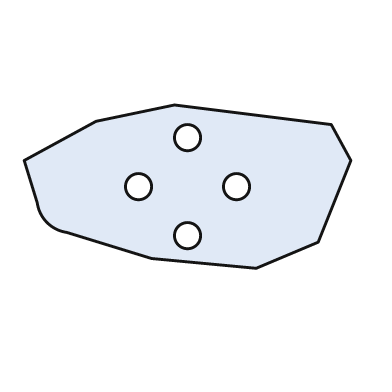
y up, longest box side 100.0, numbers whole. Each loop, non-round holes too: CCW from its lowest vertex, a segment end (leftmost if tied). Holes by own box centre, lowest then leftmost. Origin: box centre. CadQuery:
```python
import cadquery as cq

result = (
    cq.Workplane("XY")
    .moveTo(21.0, -25.0)
    .lineTo(40.0, -17.0)
    .lineTo(50.0, 8.0)
    .lineTo(44.0, 19.0)
    .lineTo(-4.0, 25.0)
    .lineTo(-28.0, 20.0)
    .lineTo(-50.0, 8.0)
    .lineTo(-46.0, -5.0)
    .threePointArc((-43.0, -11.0), (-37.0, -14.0))
    .lineTo(-11.0, -22.0)
    .close()
    .moveTo(0.0, -15.0)
    .circle(4.0)
    .moveTo(-15.0, 0.0)
    .circle(4.0)
    .moveTo(15.0, 0.0)
    .circle(4.0)
    .moveTo(0.0, 15.0)
    .circle(4.0)
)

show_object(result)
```